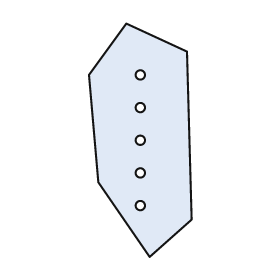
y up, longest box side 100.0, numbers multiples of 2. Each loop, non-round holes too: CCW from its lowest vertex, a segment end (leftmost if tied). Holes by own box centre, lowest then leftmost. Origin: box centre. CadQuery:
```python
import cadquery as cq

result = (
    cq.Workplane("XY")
    .moveTo(4.0, -50.0)
    .lineTo(22.0, -34.0)
    .lineTo(20.0, 38.0)
    .lineTo(-6.0, 50.0)
    .lineTo(-22.0, 28.0)
    .lineTo(-18.0, -18.0)
    .close()
    .moveTo(0.0, -28.0)
    .circle(2.0)
    .moveTo(0.0, -14.0)
    .circle(2.0)
    .moveTo(0.0, 0.0)
    .circle(2.0)
    .moveTo(0.0, 14.0)
    .circle(2.0)
    .moveTo(0.0, 28.0)
    .circle(2.0)
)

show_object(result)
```